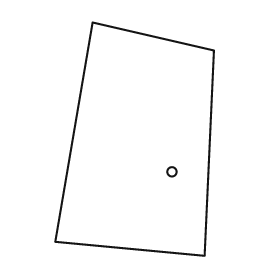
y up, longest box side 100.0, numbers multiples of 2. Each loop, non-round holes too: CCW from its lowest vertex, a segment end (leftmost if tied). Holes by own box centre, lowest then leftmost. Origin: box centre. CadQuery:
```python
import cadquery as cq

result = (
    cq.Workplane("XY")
    .moveTo(30.0, -50.0)
    .lineTo(34.0, 38.0)
    .lineTo(-18.0, 50.0)
    .lineTo(-34.0, -44.0)
    .close()
    .moveTo(16.0, -14.0)
    .circle(2.0)
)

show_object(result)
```